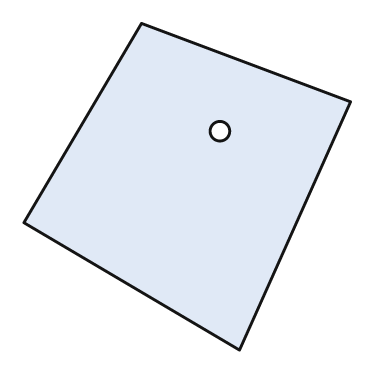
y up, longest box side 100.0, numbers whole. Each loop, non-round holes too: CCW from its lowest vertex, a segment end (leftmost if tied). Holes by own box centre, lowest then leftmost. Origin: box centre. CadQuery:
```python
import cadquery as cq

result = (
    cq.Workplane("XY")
    .moveTo(16.0, -50.0)
    .lineTo(50.0, 26.0)
    .lineTo(-14.0, 50.0)
    .lineTo(-50.0, -11.0)
    .close()
    .moveTo(10.0, 17.0)
    .circle(3.0)
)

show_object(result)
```